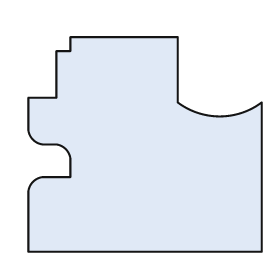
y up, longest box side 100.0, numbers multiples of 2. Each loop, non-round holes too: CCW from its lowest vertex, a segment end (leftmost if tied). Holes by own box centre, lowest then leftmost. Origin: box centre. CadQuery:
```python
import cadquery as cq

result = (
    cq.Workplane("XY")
    .moveTo(-50.0, -46.0)
    .lineTo(50.0, -46.0)
    .lineTo(50.0, 18.0)
    .threePointArc((32.0, 12.0), (14.0, 18.0))
    .lineTo(14.0, 46.0)
    .lineTo(-32.0, 46.0)
    .lineTo(-32.0, 40.0)
    .lineTo(-38.0, 40.0)
    .lineTo(-38.0, 20.0)
    .lineTo(-50.0, 20.0)
    .lineTo(-50.0, 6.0)
    .threePointArc((-48.0, 2.0), (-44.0, 0.0))
    .lineTo(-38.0, 0.0)
    .threePointArc((-34.0, -2.0), (-32.0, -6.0))
    .lineTo(-32.0, -14.0)
    .lineTo(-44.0, -14.0)
    .threePointArc((-48.0, -16.0), (-50.0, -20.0))
    .close()
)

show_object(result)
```